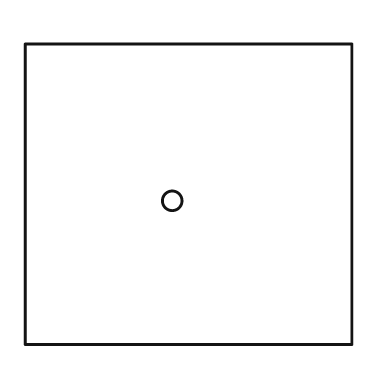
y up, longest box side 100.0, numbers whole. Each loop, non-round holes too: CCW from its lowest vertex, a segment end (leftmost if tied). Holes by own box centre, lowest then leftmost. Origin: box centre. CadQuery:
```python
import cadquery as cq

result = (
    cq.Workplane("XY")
    .moveTo(-50.0, -46.0)
    .lineTo(50.0, -46.0)
    .lineTo(50.0, 46.0)
    .lineTo(-50.0, 46.0)
    .close()
    .moveTo(-5.0, -2.0)
    .circle(3.0)
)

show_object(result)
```